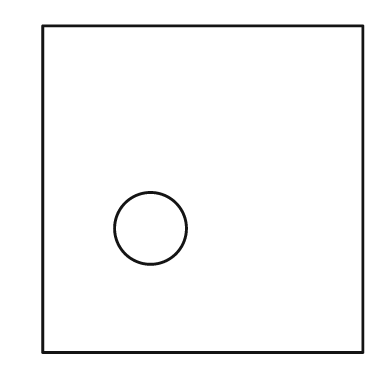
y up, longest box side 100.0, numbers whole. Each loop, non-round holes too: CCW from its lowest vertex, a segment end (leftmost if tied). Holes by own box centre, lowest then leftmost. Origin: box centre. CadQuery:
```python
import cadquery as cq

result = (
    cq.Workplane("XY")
    .moveTo(-49.0, -50.0)
    .lineTo(49.0, -50.0)
    .lineTo(49.0, 50.0)
    .lineTo(-49.0, 50.0)
    .close()
    .moveTo(-16.0, -12.0)
    .circle(11.0)
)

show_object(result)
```